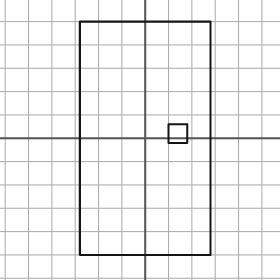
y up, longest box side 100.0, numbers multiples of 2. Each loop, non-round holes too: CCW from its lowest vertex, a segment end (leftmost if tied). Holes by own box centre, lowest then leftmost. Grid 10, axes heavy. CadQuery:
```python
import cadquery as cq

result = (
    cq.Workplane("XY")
    .moveTo(-28.0, -50.0)
    .lineTo(28.0, -50.0)
    .lineTo(28.0, 50.0)
    .lineTo(-28.0, 50.0)
    .close()
    .moveTo(10.0, -2.0)
    .lineTo(18.0, -2.0)
    .lineTo(18.0, 6.0)
    .lineTo(10.0, 6.0)
    .close()
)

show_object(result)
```